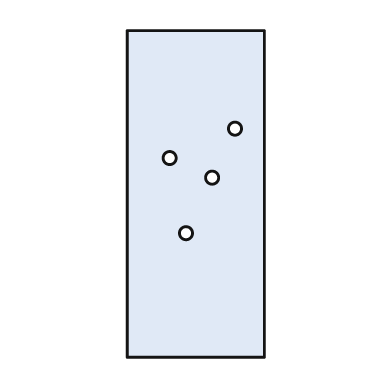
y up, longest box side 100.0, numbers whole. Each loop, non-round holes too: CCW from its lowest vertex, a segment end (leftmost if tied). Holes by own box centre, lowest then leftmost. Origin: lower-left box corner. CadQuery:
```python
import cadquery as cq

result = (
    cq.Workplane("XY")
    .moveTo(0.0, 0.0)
    .lineTo(42.0, 0.0)
    .lineTo(42.0, 100.0)
    .lineTo(0.0, 100.0)
    .close()
    .moveTo(18.0, 38.0)
    .circle(2.0)
    .moveTo(26.0, 55.0)
    .circle(2.0)
    .moveTo(13.0, 61.0)
    .circle(2.0)
    .moveTo(33.0, 70.0)
    .circle(2.0)
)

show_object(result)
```